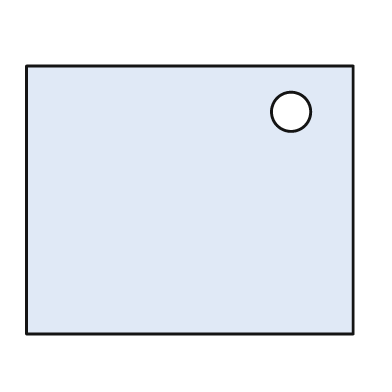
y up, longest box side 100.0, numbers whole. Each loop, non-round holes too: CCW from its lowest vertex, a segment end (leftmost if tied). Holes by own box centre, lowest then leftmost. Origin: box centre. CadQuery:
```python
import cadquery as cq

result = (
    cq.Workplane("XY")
    .moveTo(-50.0, -41.0)
    .lineTo(50.0, -41.0)
    .lineTo(50.0, 41.0)
    .lineTo(-50.0, 41.0)
    .close()
    .moveTo(31.0, 27.0)
    .circle(6.0)
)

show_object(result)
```